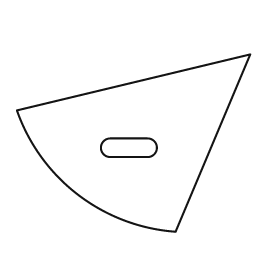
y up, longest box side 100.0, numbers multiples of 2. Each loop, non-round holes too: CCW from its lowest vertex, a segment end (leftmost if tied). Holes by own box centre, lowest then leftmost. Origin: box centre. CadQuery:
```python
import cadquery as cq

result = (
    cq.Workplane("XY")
    .moveTo(18.0, -38.0)
    .lineTo(50.0, 38.0)
    .lineTo(-50.0, 14.0)
    .threePointArc((-24.0, -22.0), (18.0, -38.0))
    .close()
    .moveTo(-10.0, -6.0)
    .lineTo(6.0, -6.0)
    .threePointArc((10.0, -2.0), (6.0, 2.0))
    .lineTo(-10.0, 2.0)
    .threePointArc((-14.0, -2.0), (-10.0, -6.0))
    .close()
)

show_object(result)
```